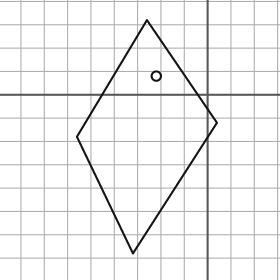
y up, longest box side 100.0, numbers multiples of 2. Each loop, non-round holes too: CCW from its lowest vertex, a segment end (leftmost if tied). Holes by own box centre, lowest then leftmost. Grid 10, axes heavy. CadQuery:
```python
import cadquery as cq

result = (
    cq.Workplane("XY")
    .moveTo(-32.0, -68.0)
    .lineTo(4.0, -12.0)
    .lineTo(-26.0, 32.0)
    .lineTo(-56.0, -18.0)
    .close()
    .moveTo(-22.0, 8.0)
    .circle(2.0)
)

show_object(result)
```